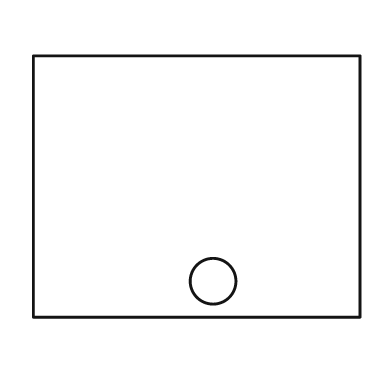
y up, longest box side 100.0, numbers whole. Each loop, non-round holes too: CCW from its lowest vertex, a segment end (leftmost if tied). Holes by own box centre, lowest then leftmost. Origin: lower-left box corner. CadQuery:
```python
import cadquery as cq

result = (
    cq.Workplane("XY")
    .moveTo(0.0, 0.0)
    .lineTo(100.0, 0.0)
    .lineTo(100.0, 80.0)
    .lineTo(0.0, 80.0)
    .close()
    .moveTo(55.0, 11.0)
    .circle(7.0)
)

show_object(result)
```